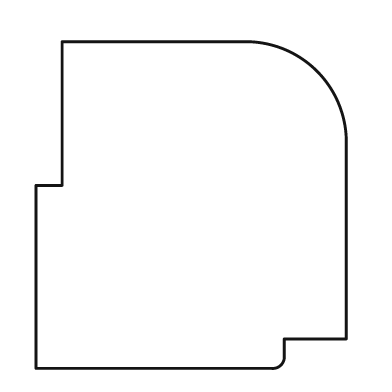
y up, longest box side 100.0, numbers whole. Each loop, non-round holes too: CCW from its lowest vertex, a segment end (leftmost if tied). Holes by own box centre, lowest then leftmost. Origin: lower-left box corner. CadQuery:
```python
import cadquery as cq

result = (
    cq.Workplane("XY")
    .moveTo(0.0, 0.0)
    .lineTo(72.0, 0.0)
    .threePointArc((75.0, 1.0), (76.0, 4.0))
    .lineTo(76.0, 9.0)
    .lineTo(95.0, 9.0)
    .lineTo(95.0, 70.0)
    .threePointArc((86.0, 91.0), (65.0, 100.0))
    .lineTo(8.0, 100.0)
    .lineTo(8.0, 56.0)
    .lineTo(0.0, 56.0)
    .close()
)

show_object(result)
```